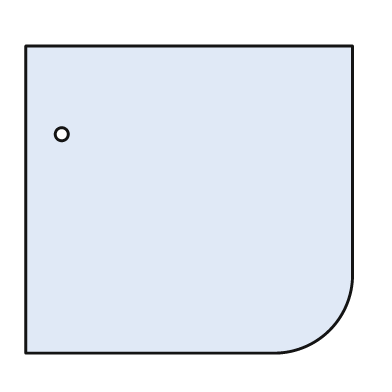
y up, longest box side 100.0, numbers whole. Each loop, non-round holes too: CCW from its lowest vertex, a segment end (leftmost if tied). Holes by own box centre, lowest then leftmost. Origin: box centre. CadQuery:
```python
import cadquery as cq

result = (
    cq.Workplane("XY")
    .moveTo(-50.0, -47.0)
    .lineTo(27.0, -47.0)
    .threePointArc((43.0, -40.0), (50.0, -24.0))
    .lineTo(50.0, 47.0)
    .lineTo(-50.0, 47.0)
    .close()
    .moveTo(-39.0, 20.0)
    .circle(2.0)
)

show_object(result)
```